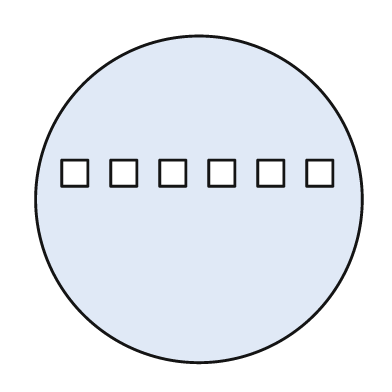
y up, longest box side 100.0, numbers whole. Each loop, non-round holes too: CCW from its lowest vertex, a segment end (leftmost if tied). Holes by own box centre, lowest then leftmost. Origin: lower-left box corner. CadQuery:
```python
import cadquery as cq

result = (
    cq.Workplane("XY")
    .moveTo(50.0, 50.0)
    .circle(50.0)
    .moveTo(8.0, 54.0)
    .lineTo(16.0, 54.0)
    .lineTo(16.0, 62.0)
    .lineTo(8.0, 62.0)
    .close()
    .moveTo(23.0, 54.0)
    .lineTo(31.0, 54.0)
    .lineTo(31.0, 62.0)
    .lineTo(23.0, 62.0)
    .close()
    .moveTo(38.0, 54.0)
    .lineTo(46.0, 54.0)
    .lineTo(46.0, 62.0)
    .lineTo(38.0, 62.0)
    .close()
    .moveTo(53.0, 54.0)
    .lineTo(61.0, 54.0)
    .lineTo(61.0, 62.0)
    .lineTo(53.0, 62.0)
    .close()
    .moveTo(68.0, 54.0)
    .lineTo(76.0, 54.0)
    .lineTo(76.0, 62.0)
    .lineTo(68.0, 62.0)
    .close()
    .moveTo(83.0, 54.0)
    .lineTo(91.0, 54.0)
    .lineTo(91.0, 62.0)
    .lineTo(83.0, 62.0)
    .close()
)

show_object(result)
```